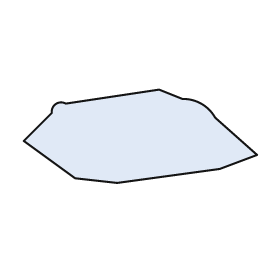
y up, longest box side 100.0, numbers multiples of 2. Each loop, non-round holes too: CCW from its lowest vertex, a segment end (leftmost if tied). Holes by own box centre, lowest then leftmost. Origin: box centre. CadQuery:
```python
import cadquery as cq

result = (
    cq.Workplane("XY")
    .moveTo(-10.0, -20.0)
    .lineTo(34.0, -14.0)
    .lineTo(50.0, -8.0)
    .lineTo(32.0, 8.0)
    .threePointArc((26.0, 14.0), (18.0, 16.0))
    .lineTo(8.0, 20.0)
    .lineTo(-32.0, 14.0)
    .threePointArc((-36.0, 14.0), (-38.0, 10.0))
    .lineTo(-50.0, -2.0)
    .lineTo(-28.0, -18.0)
    .close()
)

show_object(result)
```